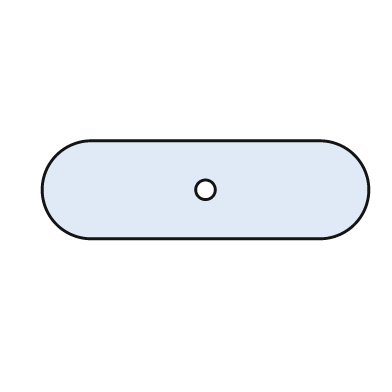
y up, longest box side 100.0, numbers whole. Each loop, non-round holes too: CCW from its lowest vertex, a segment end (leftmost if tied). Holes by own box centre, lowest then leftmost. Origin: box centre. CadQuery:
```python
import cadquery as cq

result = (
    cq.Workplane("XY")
    .moveTo(-35.0, -15.0)
    .lineTo(35.0, -15.0)
    .threePointArc((50.0, 0.0), (35.0, 15.0))
    .lineTo(-35.0, 15.0)
    .threePointArc((-50.0, 0.0), (-35.0, -15.0))
    .close()
    .moveTo(0.0, 0.0)
    .circle(3.0)
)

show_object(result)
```